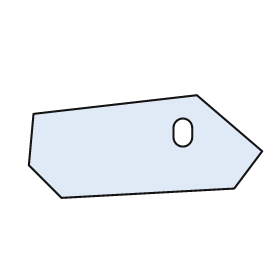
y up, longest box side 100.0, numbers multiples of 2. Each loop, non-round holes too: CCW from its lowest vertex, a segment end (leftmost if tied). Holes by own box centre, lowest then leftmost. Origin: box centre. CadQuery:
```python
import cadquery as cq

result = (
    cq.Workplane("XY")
    .moveTo(-36.0, -22.0)
    .lineTo(38.0, -18.0)
    .lineTo(50.0, -2.0)
    .lineTo(22.0, 22.0)
    .lineTo(-48.0, 14.0)
    .lineTo(-50.0, -8.0)
    .close()
    .moveTo(12.0, 4.0)
    .threePointArc((16.0, 0.0), (20.0, 4.0))
    .lineTo(20.0, 8.0)
    .threePointArc((16.0, 12.0), (12.0, 8.0))
    .close()
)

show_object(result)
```